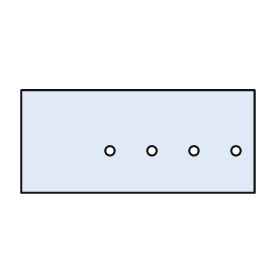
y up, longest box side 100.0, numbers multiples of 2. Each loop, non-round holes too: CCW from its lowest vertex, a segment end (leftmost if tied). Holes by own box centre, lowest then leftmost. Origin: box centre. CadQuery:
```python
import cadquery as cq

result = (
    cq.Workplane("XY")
    .moveTo(-50.0, -22.0)
    .lineTo(50.0, -22.0)
    .lineTo(50.0, 22.0)
    .lineTo(-50.0, 22.0)
    .close()
    .moveTo(-12.0, -4.0)
    .circle(2.0)
    .moveTo(6.0, -4.0)
    .circle(2.0)
    .moveTo(24.0, -4.0)
    .circle(2.0)
    .moveTo(42.0, -4.0)
    .circle(2.0)
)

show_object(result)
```